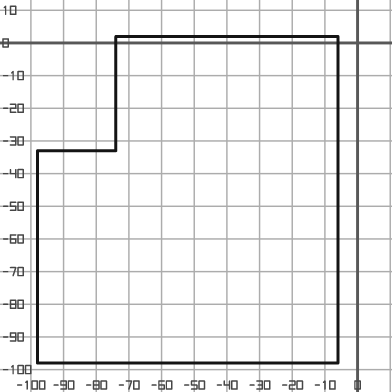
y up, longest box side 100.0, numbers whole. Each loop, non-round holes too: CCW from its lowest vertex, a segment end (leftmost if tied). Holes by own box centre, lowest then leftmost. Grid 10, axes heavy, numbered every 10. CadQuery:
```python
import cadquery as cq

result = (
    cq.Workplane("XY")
    .moveTo(-98.0, -98.0)
    .lineTo(-6.0, -98.0)
    .lineTo(-6.0, 2.0)
    .lineTo(-74.0, 2.0)
    .lineTo(-74.0, -33.0)
    .lineTo(-98.0, -33.0)
    .close()
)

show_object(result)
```